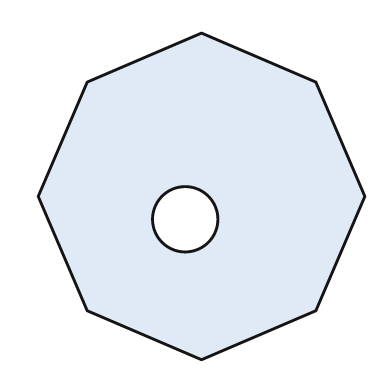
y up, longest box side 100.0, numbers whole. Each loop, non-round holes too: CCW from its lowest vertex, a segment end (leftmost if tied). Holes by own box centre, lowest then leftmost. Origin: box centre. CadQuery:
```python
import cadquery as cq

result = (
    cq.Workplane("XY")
    .moveTo(0.0, -50.0)
    .lineTo(35.0, -35.0)
    .lineTo(50.0, 0.0)
    .lineTo(35.0, 35.0)
    .lineTo(0.0, 50.0)
    .lineTo(-35.0, 35.0)
    .lineTo(-50.0, 0.0)
    .lineTo(-35.0, -35.0)
    .close()
    .moveTo(-5.0, -7.0)
    .circle(10.0)
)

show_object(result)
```